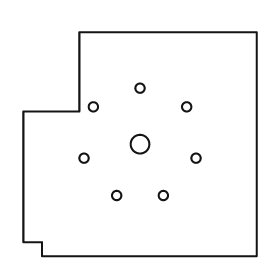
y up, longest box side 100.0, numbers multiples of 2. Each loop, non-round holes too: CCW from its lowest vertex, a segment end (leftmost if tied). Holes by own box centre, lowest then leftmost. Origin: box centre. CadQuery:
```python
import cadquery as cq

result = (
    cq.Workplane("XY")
    .moveTo(-42.0, -48.0)
    .lineTo(50.0, -48.0)
    .lineTo(50.0, 48.0)
    .lineTo(-26.0, 48.0)
    .lineTo(-26.0, 14.0)
    .lineTo(-50.0, 14.0)
    .lineTo(-50.0, -42.0)
    .lineTo(-42.0, -42.0)
    .close()
    .moveTo(-10.0, -22.0)
    .circle(2.0)
    .moveTo(10.0, -22.0)
    .circle(2.0)
    .moveTo(-24.0, -6.0)
    .circle(2.0)
    .moveTo(24.0, -6.0)
    .circle(2.0)
    .moveTo(0.0, 0.0)
    .circle(4.0)
    .moveTo(-20.0, 16.0)
    .circle(2.0)
    .moveTo(20.0, 16.0)
    .circle(2.0)
    .moveTo(0.0, 24.0)
    .circle(2.0)
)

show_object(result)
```